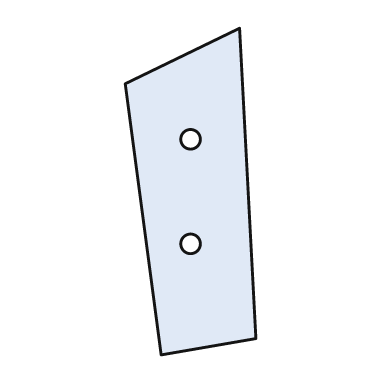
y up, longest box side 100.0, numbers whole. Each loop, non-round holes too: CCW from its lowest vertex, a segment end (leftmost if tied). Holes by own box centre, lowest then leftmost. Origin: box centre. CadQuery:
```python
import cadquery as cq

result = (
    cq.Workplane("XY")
    .moveTo(-9.0, -50.0)
    .lineTo(20.0, -45.0)
    .lineTo(15.0, 50.0)
    .lineTo(-20.0, 33.0)
    .close()
    .moveTo(0.0, -16.0)
    .circle(3.0)
    .moveTo(0.0, 16.0)
    .circle(3.0)
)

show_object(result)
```